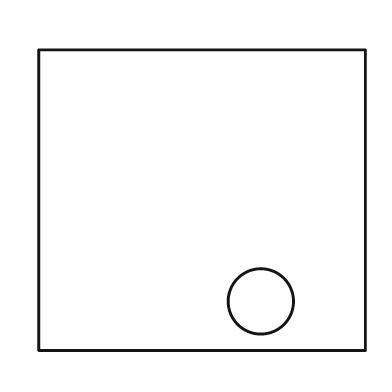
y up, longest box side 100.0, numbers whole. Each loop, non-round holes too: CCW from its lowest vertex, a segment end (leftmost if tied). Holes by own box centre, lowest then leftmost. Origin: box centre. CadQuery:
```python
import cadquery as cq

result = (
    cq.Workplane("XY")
    .moveTo(-50.0, -46.0)
    .lineTo(50.0, -46.0)
    .lineTo(50.0, 46.0)
    .lineTo(-50.0, 46.0)
    .close()
    .moveTo(18.0, -31.0)
    .circle(10.0)
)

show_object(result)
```